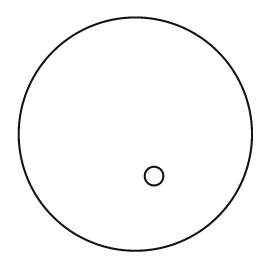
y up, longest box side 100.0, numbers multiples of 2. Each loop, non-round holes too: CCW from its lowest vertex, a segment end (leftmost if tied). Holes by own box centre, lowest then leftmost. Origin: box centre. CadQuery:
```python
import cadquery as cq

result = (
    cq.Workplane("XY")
    .moveTo(0.0, 0.0)
    .circle(50.0)
    .moveTo(8.0, -18.0)
    .circle(4.0)
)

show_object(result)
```